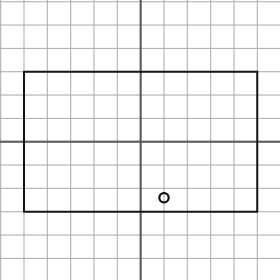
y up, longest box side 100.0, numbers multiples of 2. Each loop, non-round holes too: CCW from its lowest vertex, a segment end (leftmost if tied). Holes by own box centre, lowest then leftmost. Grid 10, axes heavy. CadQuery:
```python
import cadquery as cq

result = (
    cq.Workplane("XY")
    .moveTo(-50.0, -30.0)
    .lineTo(50.0, -30.0)
    .lineTo(50.0, 30.0)
    .lineTo(-50.0, 30.0)
    .close()
    .moveTo(10.0, -24.0)
    .circle(2.0)
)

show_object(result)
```